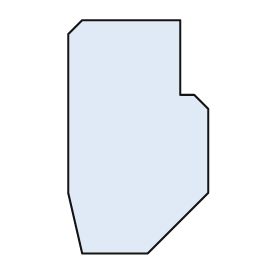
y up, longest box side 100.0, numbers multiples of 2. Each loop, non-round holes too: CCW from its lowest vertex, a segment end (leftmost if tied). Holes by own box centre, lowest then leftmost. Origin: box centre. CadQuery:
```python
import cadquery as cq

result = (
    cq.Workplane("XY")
    .moveTo(-24.0, -50.0)
    .lineTo(4.0, -50.0)
    .lineTo(30.0, -24.0)
    .lineTo(30.0, 12.0)
    .lineTo(24.0, 18.0)
    .lineTo(18.0, 18.0)
    .lineTo(18.0, 50.0)
    .lineTo(-24.0, 50.0)
    .lineTo(-30.0, 44.0)
    .lineTo(-30.0, -24.0)
    .close()
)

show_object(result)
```